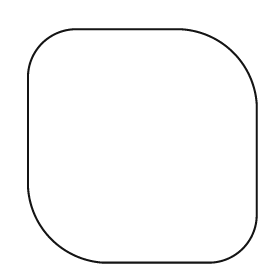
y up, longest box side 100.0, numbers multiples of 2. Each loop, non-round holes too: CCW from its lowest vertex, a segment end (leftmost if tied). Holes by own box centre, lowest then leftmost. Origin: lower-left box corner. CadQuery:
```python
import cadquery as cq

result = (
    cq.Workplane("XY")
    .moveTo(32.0, 0.0)
    .lineTo(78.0, 0.0)
    .threePointArc((92.0, 6.0), (98.0, 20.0))
    .lineTo(98.0, 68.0)
    .threePointArc((88.0, 90.0), (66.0, 100.0))
    .lineTo(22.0, 100.0)
    .threePointArc((6.0, 94.0), (0.0, 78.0))
    .lineTo(0.0, 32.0)
    .threePointArc((10.0, 10.0), (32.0, 0.0))
    .close()
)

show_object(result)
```